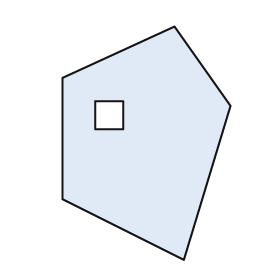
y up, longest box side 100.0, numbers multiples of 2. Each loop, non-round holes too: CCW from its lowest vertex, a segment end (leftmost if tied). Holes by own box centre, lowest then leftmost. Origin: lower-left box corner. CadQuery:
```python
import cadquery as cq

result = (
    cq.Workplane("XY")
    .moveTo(52.0, 0.0)
    .lineTo(72.0, 66.0)
    .lineTo(48.0, 100.0)
    .lineTo(0.0, 78.0)
    .lineTo(0.0, 26.0)
    .close()
    .moveTo(14.0, 56.0)
    .lineTo(26.0, 56.0)
    .lineTo(26.0, 68.0)
    .lineTo(14.0, 68.0)
    .close()
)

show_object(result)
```